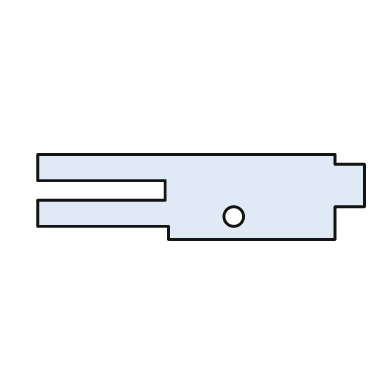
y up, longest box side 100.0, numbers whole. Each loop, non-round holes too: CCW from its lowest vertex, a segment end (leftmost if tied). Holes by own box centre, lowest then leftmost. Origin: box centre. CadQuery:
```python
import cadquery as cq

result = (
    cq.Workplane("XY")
    .moveTo(-10.0, -13.0)
    .lineTo(41.0, -13.0)
    .lineTo(41.0, -3.0)
    .lineTo(50.0, -3.0)
    .lineTo(50.0, 10.0)
    .lineTo(41.0, 10.0)
    .lineTo(41.0, 13.0)
    .lineTo(-50.0, 13.0)
    .lineTo(-50.0, 5.0)
    .lineTo(-11.0, 5.0)
    .lineTo(-11.0, -1.0)
    .lineTo(-50.0, -1.0)
    .lineTo(-50.0, -9.0)
    .lineTo(-10.0, -9.0)
    .close()
    .moveTo(10.0, -6.0)
    .circle(3.0)
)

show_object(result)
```